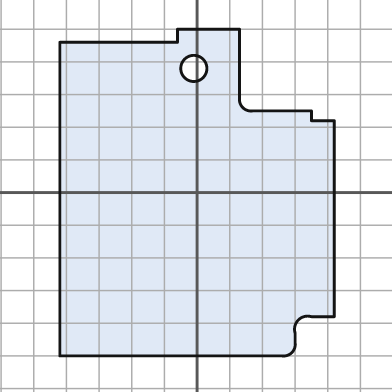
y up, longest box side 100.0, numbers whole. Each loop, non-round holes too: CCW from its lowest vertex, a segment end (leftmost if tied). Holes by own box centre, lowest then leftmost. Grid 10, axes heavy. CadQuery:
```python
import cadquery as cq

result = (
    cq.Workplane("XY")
    .moveTo(-42.0, -50.0)
    .lineTo(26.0, -50.0)
    .threePointArc((29.0, -49.0), (30.0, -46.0))
    .lineTo(30.0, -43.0)
    .threePointArc((31.0, -39.0), (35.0, -38.0))
    .lineTo(42.0, -38.0)
    .lineTo(42.0, 22.0)
    .lineTo(35.0, 22.0)
    .lineTo(35.0, 25.0)
    .lineTo(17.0, 25.0)
    .threePointArc((14.0, 26.0), (13.0, 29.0))
    .lineTo(13.0, 50.0)
    .lineTo(-6.0, 50.0)
    .lineTo(-6.0, 46.0)
    .lineTo(-42.0, 46.0)
    .close()
    .moveTo(-1.0, 38.0)
    .circle(4.0)
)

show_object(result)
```